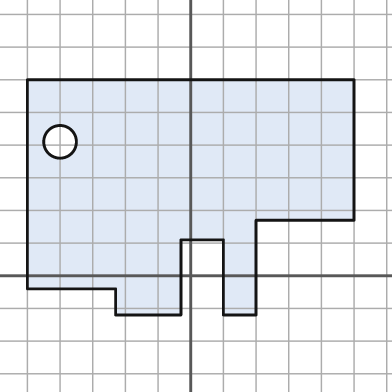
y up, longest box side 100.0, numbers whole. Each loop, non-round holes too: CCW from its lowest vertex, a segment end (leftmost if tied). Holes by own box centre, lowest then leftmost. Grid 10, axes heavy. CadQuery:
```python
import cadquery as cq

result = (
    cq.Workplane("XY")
    .moveTo(-23.0, -12.0)
    .lineTo(-3.0, -12.0)
    .lineTo(-3.0, 11.0)
    .lineTo(10.0, 11.0)
    .lineTo(10.0, -12.0)
    .lineTo(20.0, -12.0)
    .lineTo(20.0, 17.0)
    .lineTo(50.0, 17.0)
    .lineTo(50.0, 60.0)
    .lineTo(-50.0, 60.0)
    .lineTo(-50.0, -4.0)
    .lineTo(-23.0, -4.0)
    .close()
    .moveTo(-40.0, 41.0)
    .circle(5.0)
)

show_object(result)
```